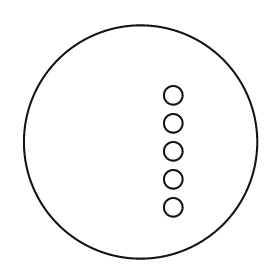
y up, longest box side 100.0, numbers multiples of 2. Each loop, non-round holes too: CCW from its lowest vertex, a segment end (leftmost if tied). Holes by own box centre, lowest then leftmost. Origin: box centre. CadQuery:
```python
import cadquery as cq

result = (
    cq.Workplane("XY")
    .moveTo(0.0, 0.0)
    .circle(50.0)
    .moveTo(14.0, -28.0)
    .circle(4.0)
    .moveTo(14.0, -16.0)
    .circle(4.0)
    .moveTo(14.0, -4.0)
    .circle(4.0)
    .moveTo(14.0, 8.0)
    .circle(4.0)
    .moveTo(14.0, 20.0)
    .circle(4.0)
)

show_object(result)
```